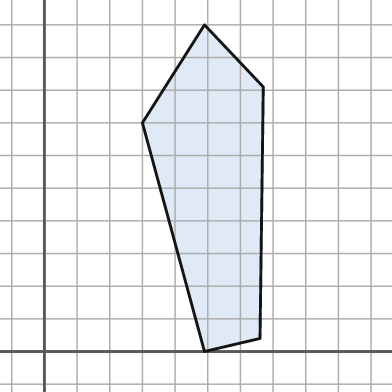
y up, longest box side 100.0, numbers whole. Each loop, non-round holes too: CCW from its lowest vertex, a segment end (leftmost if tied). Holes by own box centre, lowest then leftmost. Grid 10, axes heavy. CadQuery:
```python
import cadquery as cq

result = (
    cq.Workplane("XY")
    .moveTo(49.0, 0.0)
    .lineTo(66.0, 4.0)
    .lineTo(67.0, 81.0)
    .lineTo(49.0, 100.0)
    .lineTo(30.0, 70.0)
    .close()
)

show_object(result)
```